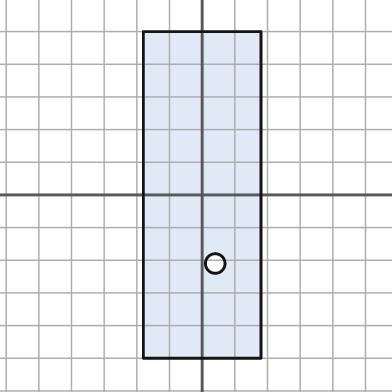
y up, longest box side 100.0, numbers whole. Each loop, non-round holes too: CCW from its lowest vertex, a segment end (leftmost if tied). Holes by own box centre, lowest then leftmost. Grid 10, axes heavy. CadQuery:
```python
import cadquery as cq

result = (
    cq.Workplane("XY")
    .moveTo(-18.0, -50.0)
    .lineTo(18.0, -50.0)
    .lineTo(18.0, 50.0)
    .lineTo(-18.0, 50.0)
    .close()
    .moveTo(4.0, -21.0)
    .circle(3.0)
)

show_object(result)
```